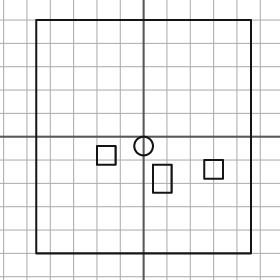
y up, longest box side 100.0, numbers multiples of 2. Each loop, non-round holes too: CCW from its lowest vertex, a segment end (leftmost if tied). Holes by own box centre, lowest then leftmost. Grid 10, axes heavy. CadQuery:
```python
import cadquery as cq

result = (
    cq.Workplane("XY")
    .moveTo(-46.0, -50.0)
    .lineTo(46.0, -50.0)
    .lineTo(46.0, 50.0)
    .lineTo(-46.0, 50.0)
    .close()
    .moveTo(4.0, -24.0)
    .lineTo(12.0, -24.0)
    .lineTo(12.0, -12.0)
    .lineTo(4.0, -12.0)
    .close()
    .moveTo(26.0, -18.0)
    .lineTo(34.0, -18.0)
    .lineTo(34.0, -10.0)
    .lineTo(26.0, -10.0)
    .close()
    .moveTo(-20.0, -12.0)
    .lineTo(-12.0, -12.0)
    .lineTo(-12.0, -4.0)
    .lineTo(-20.0, -4.0)
    .close()
    .moveTo(0.0, -4.0)
    .circle(4.0)
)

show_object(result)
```